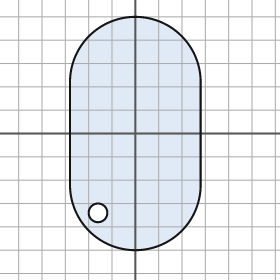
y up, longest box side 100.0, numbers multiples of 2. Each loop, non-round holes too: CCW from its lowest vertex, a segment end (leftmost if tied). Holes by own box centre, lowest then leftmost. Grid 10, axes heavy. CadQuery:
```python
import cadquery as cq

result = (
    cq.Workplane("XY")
    .moveTo(-28.0, -22.0)
    .threePointArc((0.0, -50.0), (28.0, -22.0))
    .lineTo(28.0, 22.0)
    .threePointArc((0.0, 50.0), (-28.0, 22.0))
    .close()
    .moveTo(-16.0, -34.0)
    .circle(4.0)
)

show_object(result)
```